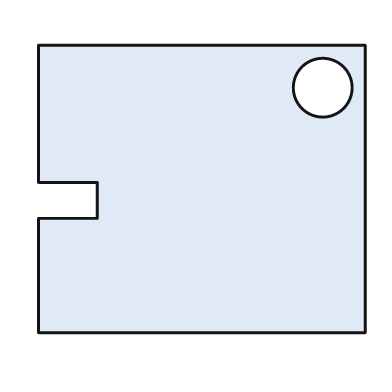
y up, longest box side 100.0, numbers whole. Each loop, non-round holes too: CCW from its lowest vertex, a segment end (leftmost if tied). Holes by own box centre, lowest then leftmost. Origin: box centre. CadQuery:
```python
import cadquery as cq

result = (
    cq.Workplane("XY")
    .moveTo(-50.0, -44.0)
    .lineTo(50.0, -44.0)
    .lineTo(50.0, 44.0)
    .lineTo(-50.0, 44.0)
    .lineTo(-50.0, 2.0)
    .lineTo(-32.0, 2.0)
    .lineTo(-32.0, -9.0)
    .lineTo(-50.0, -9.0)
    .close()
    .moveTo(37.0, 31.0)
    .circle(9.0)
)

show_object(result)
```